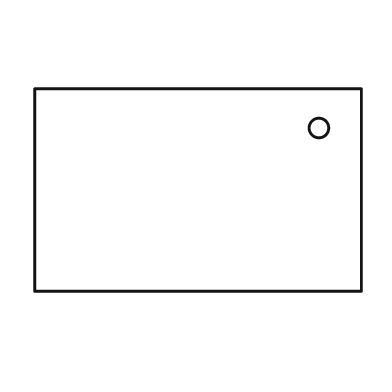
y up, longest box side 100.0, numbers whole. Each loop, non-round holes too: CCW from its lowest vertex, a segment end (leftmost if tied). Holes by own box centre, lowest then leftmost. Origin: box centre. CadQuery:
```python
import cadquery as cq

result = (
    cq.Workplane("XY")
    .moveTo(-50.0, -31.0)
    .lineTo(50.0, -31.0)
    .lineTo(50.0, 31.0)
    .lineTo(-50.0, 31.0)
    .close()
    .moveTo(37.0, 19.0)
    .circle(3.0)
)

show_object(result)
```